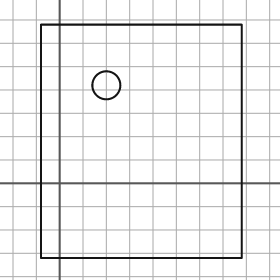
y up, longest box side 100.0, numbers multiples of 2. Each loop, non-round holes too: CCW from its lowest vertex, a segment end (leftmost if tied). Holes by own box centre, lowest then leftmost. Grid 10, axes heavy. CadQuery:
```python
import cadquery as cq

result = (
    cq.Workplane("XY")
    .moveTo(-8.0, -32.0)
    .lineTo(78.0, -32.0)
    .lineTo(78.0, 68.0)
    .lineTo(-8.0, 68.0)
    .close()
    .moveTo(20.0, 42.0)
    .circle(6.0)
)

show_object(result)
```